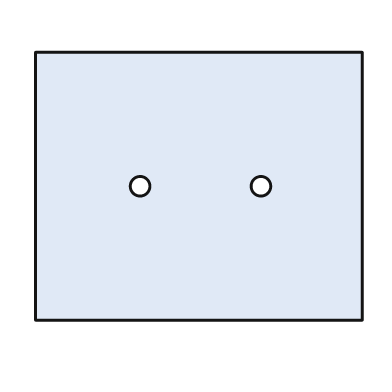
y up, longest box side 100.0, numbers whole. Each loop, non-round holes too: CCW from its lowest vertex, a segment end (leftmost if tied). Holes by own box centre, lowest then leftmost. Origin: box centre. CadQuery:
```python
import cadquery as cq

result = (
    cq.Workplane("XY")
    .moveTo(-50.0, -41.0)
    .lineTo(50.0, -41.0)
    .lineTo(50.0, 41.0)
    .lineTo(-50.0, 41.0)
    .close()
    .moveTo(-18.0, 0.0)
    .circle(3.0)
    .moveTo(19.0, 0.0)
    .circle(3.0)
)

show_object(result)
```